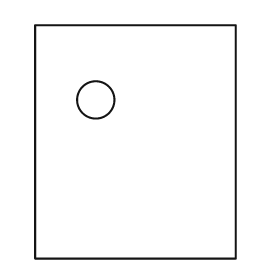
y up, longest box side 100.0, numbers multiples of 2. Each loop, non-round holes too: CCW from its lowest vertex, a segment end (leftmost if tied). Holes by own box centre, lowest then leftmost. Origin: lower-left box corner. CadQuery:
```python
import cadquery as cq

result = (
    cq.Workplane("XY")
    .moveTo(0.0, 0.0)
    .lineTo(86.0, 0.0)
    .lineTo(86.0, 100.0)
    .lineTo(0.0, 100.0)
    .close()
    .moveTo(26.0, 68.0)
    .circle(8.0)
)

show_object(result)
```